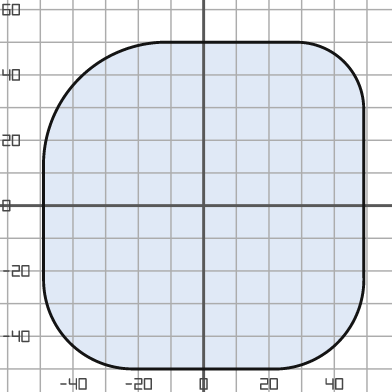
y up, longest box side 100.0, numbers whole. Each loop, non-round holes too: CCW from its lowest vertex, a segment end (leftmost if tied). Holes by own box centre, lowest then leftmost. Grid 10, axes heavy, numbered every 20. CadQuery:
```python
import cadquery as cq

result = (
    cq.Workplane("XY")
    .moveTo(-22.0, -50.0)
    .lineTo(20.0, -50.0)
    .threePointArc((41.0, -42.0), (49.0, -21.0))
    .lineTo(49.0, 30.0)
    .threePointArc((43.0, 44.0), (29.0, 50.0))
    .lineTo(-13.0, 50.0)
    .threePointArc((-38.0, 39.0), (-49.0, 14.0))
    .lineTo(-49.0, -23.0)
    .threePointArc((-41.0, -42.0), (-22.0, -50.0))
    .close()
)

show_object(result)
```